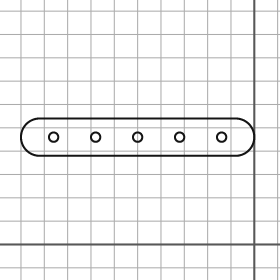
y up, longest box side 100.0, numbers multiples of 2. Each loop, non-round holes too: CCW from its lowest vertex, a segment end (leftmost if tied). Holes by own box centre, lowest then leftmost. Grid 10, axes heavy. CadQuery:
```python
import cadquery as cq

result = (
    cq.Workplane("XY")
    .moveTo(-92.0, 38.0)
    .lineTo(-8.0, 38.0)
    .threePointArc((0.0, 46.0), (-8.0, 54.0))
    .lineTo(-92.0, 54.0)
    .threePointArc((-100.0, 46.0), (-92.0, 38.0))
    .close()
    .moveTo(-86.0, 46.0)
    .circle(2.0)
    .moveTo(-68.0, 46.0)
    .circle(2.0)
    .moveTo(-50.0, 46.0)
    .circle(2.0)
    .moveTo(-32.0, 46.0)
    .circle(2.0)
    .moveTo(-14.0, 46.0)
    .circle(2.0)
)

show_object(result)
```